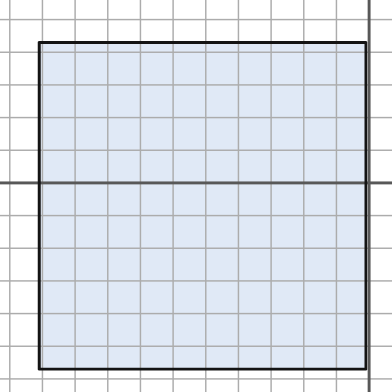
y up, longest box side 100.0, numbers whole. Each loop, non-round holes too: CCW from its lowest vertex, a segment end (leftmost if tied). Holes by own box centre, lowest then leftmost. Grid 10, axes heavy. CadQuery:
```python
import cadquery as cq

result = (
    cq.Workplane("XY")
    .moveTo(-101.0, -57.0)
    .lineTo(-1.0, -57.0)
    .lineTo(-1.0, 43.0)
    .lineTo(-101.0, 43.0)
    .close()
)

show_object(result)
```